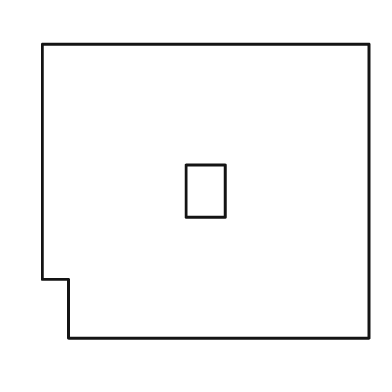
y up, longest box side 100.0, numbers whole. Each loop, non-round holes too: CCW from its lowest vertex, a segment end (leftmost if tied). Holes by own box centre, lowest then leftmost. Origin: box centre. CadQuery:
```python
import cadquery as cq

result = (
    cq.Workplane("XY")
    .moveTo(-42.0, -45.0)
    .lineTo(50.0, -45.0)
    .lineTo(50.0, 45.0)
    .lineTo(-50.0, 45.0)
    .lineTo(-50.0, -27.0)
    .lineTo(-42.0, -27.0)
    .close()
    .moveTo(-6.0, -8.0)
    .lineTo(6.0, -8.0)
    .lineTo(6.0, 8.0)
    .lineTo(-6.0, 8.0)
    .close()
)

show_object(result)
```